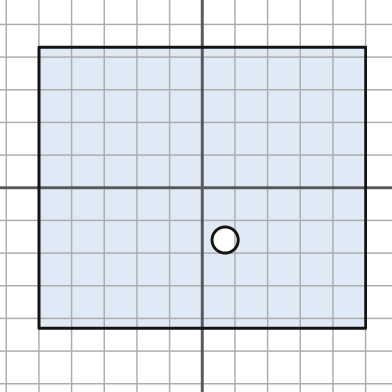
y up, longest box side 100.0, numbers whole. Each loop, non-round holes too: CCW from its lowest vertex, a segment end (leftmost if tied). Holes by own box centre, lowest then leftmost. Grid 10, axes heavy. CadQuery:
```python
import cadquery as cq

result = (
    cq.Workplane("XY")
    .moveTo(-50.0, -43.0)
    .lineTo(50.0, -43.0)
    .lineTo(50.0, 43.0)
    .lineTo(-50.0, 43.0)
    .close()
    .moveTo(7.0, -16.0)
    .circle(4.0)
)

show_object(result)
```